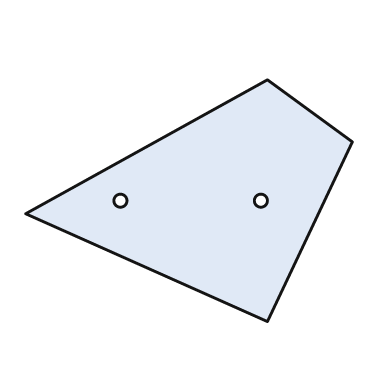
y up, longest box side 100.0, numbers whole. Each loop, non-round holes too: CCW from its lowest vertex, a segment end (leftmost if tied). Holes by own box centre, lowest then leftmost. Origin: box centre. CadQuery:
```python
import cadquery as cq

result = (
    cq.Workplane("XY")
    .moveTo(24.0, -37.0)
    .lineTo(50.0, 18.0)
    .lineTo(24.0, 37.0)
    .lineTo(-50.0, -4.0)
    .close()
    .moveTo(-21.0, 0.0)
    .circle(2.0)
    .moveTo(22.0, 0.0)
    .circle(2.0)
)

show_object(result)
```